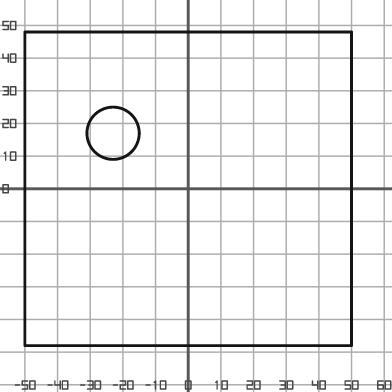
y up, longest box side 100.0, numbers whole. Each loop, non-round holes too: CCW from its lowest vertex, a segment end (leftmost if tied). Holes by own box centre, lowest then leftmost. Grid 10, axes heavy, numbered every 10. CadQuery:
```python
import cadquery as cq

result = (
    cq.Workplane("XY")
    .moveTo(-50.0, -48.0)
    .lineTo(50.0, -48.0)
    .lineTo(50.0, 48.0)
    .lineTo(-50.0, 48.0)
    .close()
    .moveTo(-23.0, 17.0)
    .circle(8.0)
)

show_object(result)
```